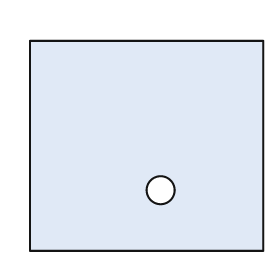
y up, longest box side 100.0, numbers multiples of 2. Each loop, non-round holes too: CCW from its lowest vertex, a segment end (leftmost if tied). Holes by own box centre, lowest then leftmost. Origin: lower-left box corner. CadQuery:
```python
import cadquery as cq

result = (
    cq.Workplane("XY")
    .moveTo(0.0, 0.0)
    .lineTo(100.0, 0.0)
    .lineTo(100.0, 90.0)
    .lineTo(0.0, 90.0)
    .close()
    .moveTo(56.0, 26.0)
    .circle(6.0)
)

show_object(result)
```